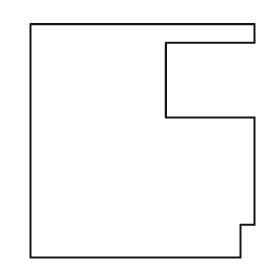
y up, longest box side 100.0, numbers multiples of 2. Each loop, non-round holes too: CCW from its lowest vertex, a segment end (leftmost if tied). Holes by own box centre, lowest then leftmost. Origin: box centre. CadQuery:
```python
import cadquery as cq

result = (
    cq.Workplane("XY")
    .moveTo(-48.0, -50.0)
    .lineTo(42.0, -50.0)
    .lineTo(42.0, -36.0)
    .lineTo(48.0, -36.0)
    .lineTo(48.0, 10.0)
    .lineTo(10.0, 10.0)
    .lineTo(10.0, 42.0)
    .lineTo(48.0, 42.0)
    .lineTo(48.0, 50.0)
    .lineTo(-48.0, 50.0)
    .close()
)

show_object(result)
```